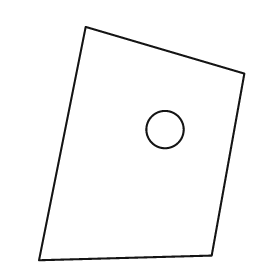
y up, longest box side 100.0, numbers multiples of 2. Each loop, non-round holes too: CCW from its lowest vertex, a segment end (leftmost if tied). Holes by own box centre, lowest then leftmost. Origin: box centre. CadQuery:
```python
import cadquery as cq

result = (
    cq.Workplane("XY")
    .moveTo(-44.0, -50.0)
    .lineTo(30.0, -48.0)
    .lineTo(44.0, 30.0)
    .lineTo(-24.0, 50.0)
    .close()
    .moveTo(10.0, 6.0)
    .circle(8.0)
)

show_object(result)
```